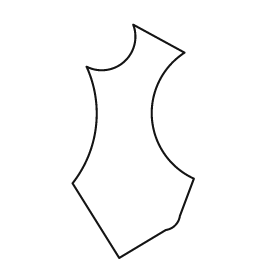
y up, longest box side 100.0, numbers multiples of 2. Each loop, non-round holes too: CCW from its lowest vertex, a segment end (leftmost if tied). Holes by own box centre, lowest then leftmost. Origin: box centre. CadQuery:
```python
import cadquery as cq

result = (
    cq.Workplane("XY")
    .moveTo(-6.0, -50.0)
    .lineTo(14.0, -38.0)
    .threePointArc((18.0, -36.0), (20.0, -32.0))
    .lineTo(26.0, -16.0)
    .threePointArc((8.0, 10.0), (22.0, 38.0))
    .lineTo(0.0, 50.0)
    .threePointArc((-4.0, 34.0), (-20.0, 32.0))
    .threePointArc((-16.0, 6.0), (-26.0, -18.0))
    .close()
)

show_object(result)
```